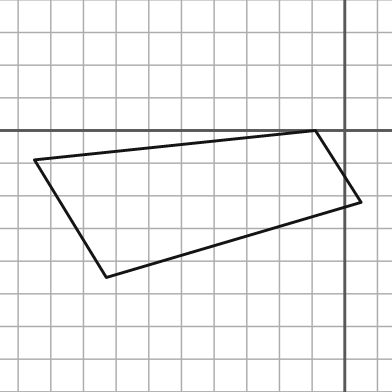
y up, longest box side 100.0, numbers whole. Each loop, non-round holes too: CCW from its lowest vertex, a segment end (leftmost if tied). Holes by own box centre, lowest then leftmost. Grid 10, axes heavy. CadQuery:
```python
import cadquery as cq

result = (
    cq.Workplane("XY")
    .moveTo(-73.0, -45.0)
    .lineTo(5.0, -22.0)
    .lineTo(-9.0, 0.0)
    .lineTo(-95.0, -9.0)
    .close()
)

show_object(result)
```